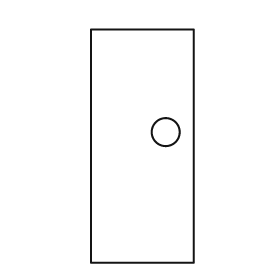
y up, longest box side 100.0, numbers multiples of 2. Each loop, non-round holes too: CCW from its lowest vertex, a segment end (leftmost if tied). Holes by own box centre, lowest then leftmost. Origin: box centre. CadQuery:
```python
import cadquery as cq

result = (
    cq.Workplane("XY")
    .moveTo(-22.0, -50.0)
    .lineTo(22.0, -50.0)
    .lineTo(22.0, 50.0)
    .lineTo(-22.0, 50.0)
    .close()
    .moveTo(10.0, 6.0)
    .circle(6.0)
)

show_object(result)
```